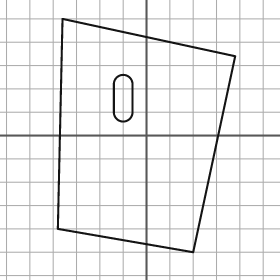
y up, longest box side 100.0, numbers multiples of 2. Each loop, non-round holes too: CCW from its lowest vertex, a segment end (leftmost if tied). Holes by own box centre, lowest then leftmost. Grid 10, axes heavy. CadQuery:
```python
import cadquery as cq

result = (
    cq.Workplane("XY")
    .moveTo(20.0, -50.0)
    .lineTo(38.0, 34.0)
    .lineTo(-36.0, 50.0)
    .lineTo(-38.0, -40.0)
    .close()
    .moveTo(-14.0, 10.0)
    .threePointArc((-10.0, 6.0), (-6.0, 10.0))
    .lineTo(-6.0, 22.0)
    .threePointArc((-10.0, 26.0), (-14.0, 22.0))
    .close()
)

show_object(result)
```